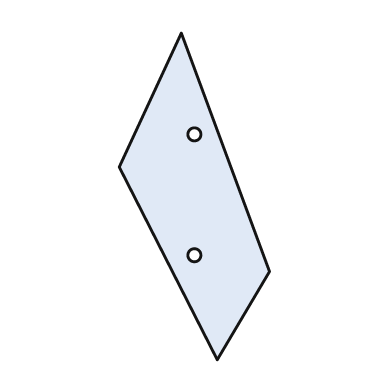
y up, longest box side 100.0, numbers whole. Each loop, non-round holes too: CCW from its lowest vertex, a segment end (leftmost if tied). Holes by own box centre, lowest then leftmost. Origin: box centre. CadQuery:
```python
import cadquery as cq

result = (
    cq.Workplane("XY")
    .moveTo(7.0, -50.0)
    .lineTo(23.0, -23.0)
    .lineTo(-4.0, 50.0)
    .lineTo(-23.0, 9.0)
    .close()
    .moveTo(0.0, -18.0)
    .circle(2.0)
    .moveTo(0.0, 19.0)
    .circle(2.0)
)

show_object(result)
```